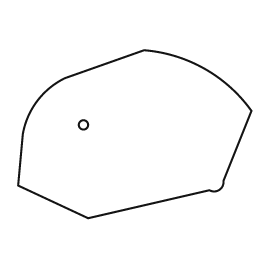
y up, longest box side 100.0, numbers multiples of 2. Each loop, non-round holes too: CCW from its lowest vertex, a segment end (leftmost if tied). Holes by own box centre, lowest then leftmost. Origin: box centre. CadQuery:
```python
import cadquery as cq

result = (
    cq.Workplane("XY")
    .moveTo(-20.0, -36.0)
    .lineTo(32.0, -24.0)
    .threePointArc((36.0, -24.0), (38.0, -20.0))
    .lineTo(50.0, 10.0)
    .threePointArc((30.0, 28.0), (4.0, 36.0))
    .lineTo(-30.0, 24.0)
    .threePointArc((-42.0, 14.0), (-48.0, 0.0))
    .lineTo(-50.0, -22.0)
    .close()
    .moveTo(-22.0, 4.0)
    .circle(2.0)
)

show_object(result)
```